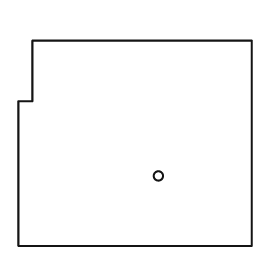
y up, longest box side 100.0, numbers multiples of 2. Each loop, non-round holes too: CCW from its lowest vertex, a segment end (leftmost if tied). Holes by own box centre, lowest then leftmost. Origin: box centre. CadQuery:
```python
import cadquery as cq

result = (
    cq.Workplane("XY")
    .moveTo(-50.0, -44.0)
    .lineTo(50.0, -44.0)
    .lineTo(50.0, 44.0)
    .lineTo(-44.0, 44.0)
    .lineTo(-44.0, 18.0)
    .lineTo(-50.0, 18.0)
    .close()
    .moveTo(10.0, -14.0)
    .circle(2.0)
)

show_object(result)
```